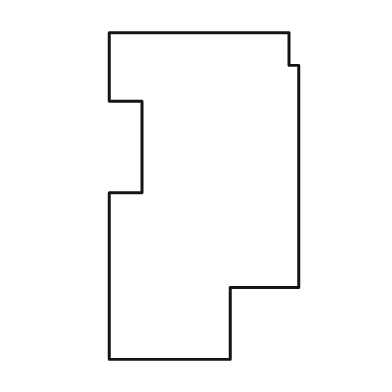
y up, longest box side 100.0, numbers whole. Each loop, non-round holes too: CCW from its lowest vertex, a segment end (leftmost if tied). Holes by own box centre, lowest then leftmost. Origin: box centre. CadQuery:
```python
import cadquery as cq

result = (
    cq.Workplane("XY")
    .moveTo(-29.0, -50.0)
    .lineTo(8.0, -50.0)
    .lineTo(8.0, -28.0)
    .lineTo(29.0, -28.0)
    .lineTo(29.0, 40.0)
    .lineTo(26.0, 40.0)
    .lineTo(26.0, 50.0)
    .lineTo(-29.0, 50.0)
    .lineTo(-29.0, 29.0)
    .lineTo(-19.0, 29.0)
    .lineTo(-19.0, 1.0)
    .lineTo(-29.0, 1.0)
    .close()
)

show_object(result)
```